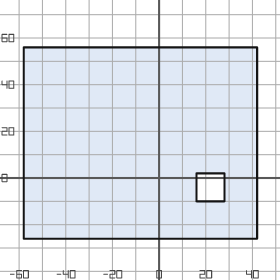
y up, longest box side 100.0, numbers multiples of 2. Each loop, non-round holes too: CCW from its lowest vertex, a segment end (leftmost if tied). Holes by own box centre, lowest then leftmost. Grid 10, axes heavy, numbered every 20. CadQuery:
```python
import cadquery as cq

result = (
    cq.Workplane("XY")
    .moveTo(-58.0, -26.0)
    .lineTo(42.0, -26.0)
    .lineTo(42.0, 56.0)
    .lineTo(-58.0, 56.0)
    .close()
    .moveTo(16.0, -10.0)
    .lineTo(28.0, -10.0)
    .lineTo(28.0, 2.0)
    .lineTo(16.0, 2.0)
    .close()
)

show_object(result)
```